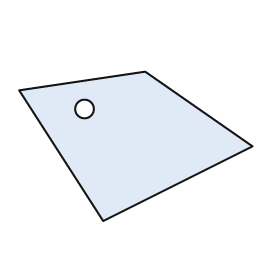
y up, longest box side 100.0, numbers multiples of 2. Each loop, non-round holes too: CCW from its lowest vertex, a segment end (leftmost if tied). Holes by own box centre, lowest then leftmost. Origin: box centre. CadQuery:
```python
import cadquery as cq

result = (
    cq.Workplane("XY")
    .moveTo(-14.0, -32.0)
    .lineTo(50.0, 0.0)
    .lineTo(4.0, 32.0)
    .lineTo(-50.0, 24.0)
    .close()
    .moveTo(-22.0, 16.0)
    .circle(4.0)
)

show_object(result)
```